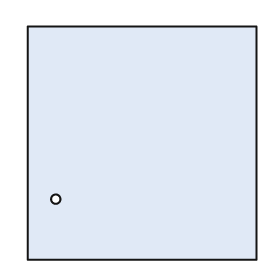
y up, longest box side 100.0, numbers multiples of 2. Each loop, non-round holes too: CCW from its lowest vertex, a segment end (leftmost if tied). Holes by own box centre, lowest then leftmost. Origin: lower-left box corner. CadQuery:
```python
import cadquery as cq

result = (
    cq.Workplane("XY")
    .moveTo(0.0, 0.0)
    .lineTo(98.0, 0.0)
    .lineTo(98.0, 100.0)
    .lineTo(0.0, 100.0)
    .close()
    .moveTo(12.0, 26.0)
    .circle(2.0)
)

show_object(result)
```